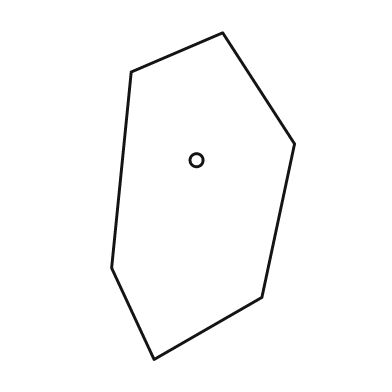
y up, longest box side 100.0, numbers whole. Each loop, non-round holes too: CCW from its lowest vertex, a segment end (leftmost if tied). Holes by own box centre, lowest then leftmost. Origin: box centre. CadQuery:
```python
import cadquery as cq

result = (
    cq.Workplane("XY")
    .moveTo(-15.0, -50.0)
    .lineTo(18.0, -31.0)
    .lineTo(28.0, 16.0)
    .lineTo(6.0, 50.0)
    .lineTo(-22.0, 38.0)
    .lineTo(-28.0, -22.0)
    .close()
    .moveTo(-2.0, 11.0)
    .circle(2.0)
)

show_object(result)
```